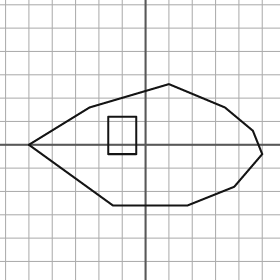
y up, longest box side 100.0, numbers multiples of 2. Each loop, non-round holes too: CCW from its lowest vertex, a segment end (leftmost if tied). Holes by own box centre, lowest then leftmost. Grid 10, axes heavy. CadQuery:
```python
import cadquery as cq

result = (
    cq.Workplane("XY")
    .moveTo(-14.0, -26.0)
    .lineTo(18.0, -26.0)
    .lineTo(38.0, -18.0)
    .lineTo(50.0, -4.0)
    .lineTo(46.0, 6.0)
    .lineTo(34.0, 16.0)
    .lineTo(10.0, 26.0)
    .lineTo(-24.0, 16.0)
    .lineTo(-50.0, 0.0)
    .close()
    .moveTo(-16.0, -4.0)
    .lineTo(-4.0, -4.0)
    .lineTo(-4.0, 12.0)
    .lineTo(-16.0, 12.0)
    .close()
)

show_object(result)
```